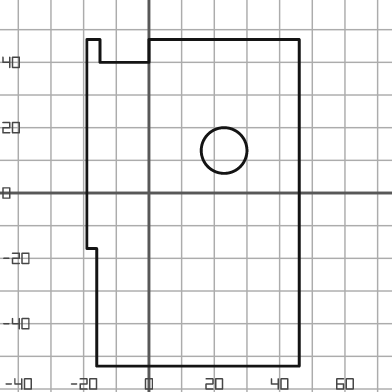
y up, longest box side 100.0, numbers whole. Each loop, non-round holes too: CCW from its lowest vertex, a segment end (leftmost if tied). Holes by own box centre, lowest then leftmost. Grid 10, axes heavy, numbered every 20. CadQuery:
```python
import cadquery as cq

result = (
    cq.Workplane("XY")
    .moveTo(-16.0, -53.0)
    .lineTo(46.0, -53.0)
    .lineTo(46.0, 47.0)
    .lineTo(0.0, 47.0)
    .lineTo(0.0, 40.0)
    .lineTo(-15.0, 40.0)
    .lineTo(-15.0, 47.0)
    .lineTo(-19.0, 47.0)
    .lineTo(-19.0, -17.0)
    .lineTo(-16.0, -17.0)
    .close()
    .moveTo(23.0, 13.0)
    .circle(7.0)
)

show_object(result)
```